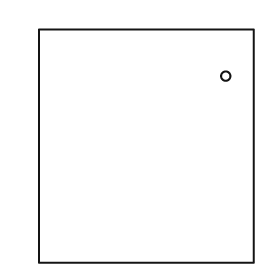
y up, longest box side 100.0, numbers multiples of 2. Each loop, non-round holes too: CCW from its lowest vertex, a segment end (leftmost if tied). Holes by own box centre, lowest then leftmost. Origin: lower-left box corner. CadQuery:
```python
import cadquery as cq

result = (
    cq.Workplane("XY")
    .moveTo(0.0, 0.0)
    .lineTo(92.0, 0.0)
    .lineTo(92.0, 100.0)
    .lineTo(0.0, 100.0)
    .close()
    .moveTo(80.0, 80.0)
    .circle(2.0)
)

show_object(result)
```